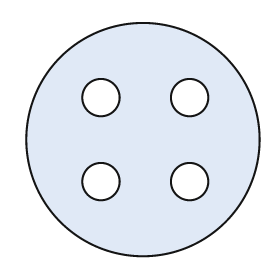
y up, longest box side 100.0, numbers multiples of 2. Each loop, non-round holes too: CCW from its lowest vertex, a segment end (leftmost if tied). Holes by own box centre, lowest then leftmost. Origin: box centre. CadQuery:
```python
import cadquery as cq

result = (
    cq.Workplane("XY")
    .moveTo(0.0, 0.0)
    .circle(50.0)
    .moveTo(-18.0, -18.0)
    .circle(8.0)
    .moveTo(20.0, -18.0)
    .circle(8.0)
    .moveTo(-18.0, 18.0)
    .circle(8.0)
    .moveTo(20.0, 18.0)
    .circle(8.0)
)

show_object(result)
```